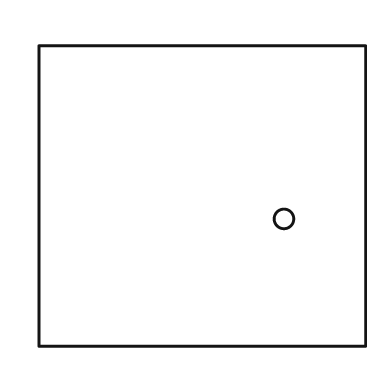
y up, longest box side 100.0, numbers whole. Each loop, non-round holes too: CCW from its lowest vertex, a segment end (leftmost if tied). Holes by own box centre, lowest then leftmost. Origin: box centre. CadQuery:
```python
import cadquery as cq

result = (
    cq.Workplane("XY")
    .moveTo(-50.0, -46.0)
    .lineTo(50.0, -46.0)
    .lineTo(50.0, 46.0)
    .lineTo(-50.0, 46.0)
    .close()
    .moveTo(25.0, -7.0)
    .circle(3.0)
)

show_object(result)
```